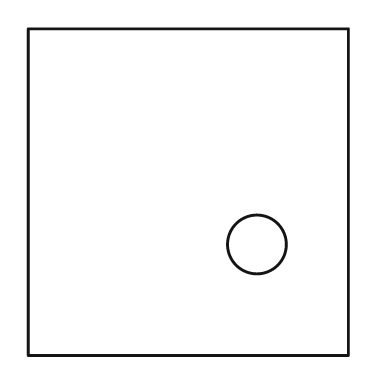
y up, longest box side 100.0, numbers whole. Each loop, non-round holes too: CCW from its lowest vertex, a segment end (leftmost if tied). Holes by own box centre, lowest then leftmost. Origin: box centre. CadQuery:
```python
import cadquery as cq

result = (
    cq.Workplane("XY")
    .moveTo(-49.0, -50.0)
    .lineTo(49.0, -50.0)
    .lineTo(49.0, 50.0)
    .lineTo(-49.0, 50.0)
    .close()
    .moveTo(21.0, -16.0)
    .circle(9.0)
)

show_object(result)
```